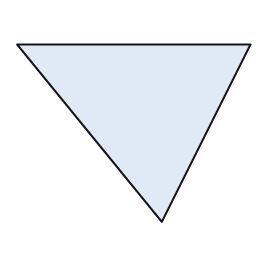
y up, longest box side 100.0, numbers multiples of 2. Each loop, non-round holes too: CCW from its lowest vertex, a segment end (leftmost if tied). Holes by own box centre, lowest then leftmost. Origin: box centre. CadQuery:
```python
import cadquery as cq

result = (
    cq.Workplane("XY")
    .moveTo(12.0, -38.0)
    .lineTo(50.0, 38.0)
    .lineTo(-50.0, 38.0)
    .close()
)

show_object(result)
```